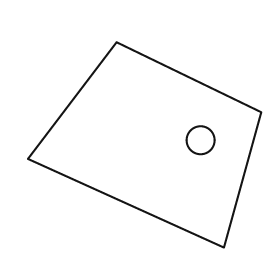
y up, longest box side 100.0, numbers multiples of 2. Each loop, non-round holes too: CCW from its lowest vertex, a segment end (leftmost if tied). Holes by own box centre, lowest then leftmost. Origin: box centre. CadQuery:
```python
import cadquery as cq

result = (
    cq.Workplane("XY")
    .moveTo(34.0, -44.0)
    .lineTo(50.0, 14.0)
    .lineTo(-12.0, 44.0)
    .lineTo(-50.0, -6.0)
    .close()
    .moveTo(24.0, 2.0)
    .circle(6.0)
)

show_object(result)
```